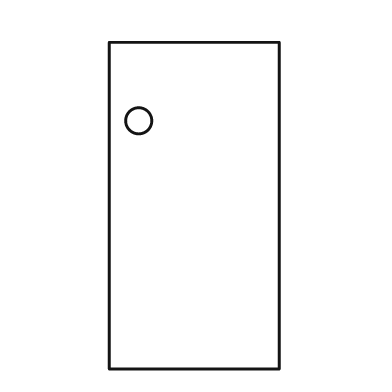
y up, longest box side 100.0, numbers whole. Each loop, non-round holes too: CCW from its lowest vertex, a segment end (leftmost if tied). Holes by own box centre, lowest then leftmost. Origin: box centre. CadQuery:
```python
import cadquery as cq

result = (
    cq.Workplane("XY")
    .moveTo(-26.0, -50.0)
    .lineTo(26.0, -50.0)
    .lineTo(26.0, 50.0)
    .lineTo(-26.0, 50.0)
    .close()
    .moveTo(-17.0, 26.0)
    .circle(4.0)
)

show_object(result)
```